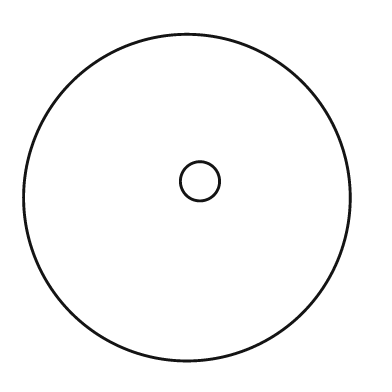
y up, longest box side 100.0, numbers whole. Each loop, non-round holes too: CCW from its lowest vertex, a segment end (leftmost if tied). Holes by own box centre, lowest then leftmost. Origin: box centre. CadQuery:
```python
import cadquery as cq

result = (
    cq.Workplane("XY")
    .moveTo(0.0, 0.0)
    .circle(50.0)
    .moveTo(4.0, 5.0)
    .circle(6.0)
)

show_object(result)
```